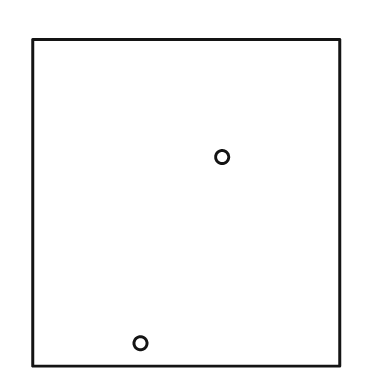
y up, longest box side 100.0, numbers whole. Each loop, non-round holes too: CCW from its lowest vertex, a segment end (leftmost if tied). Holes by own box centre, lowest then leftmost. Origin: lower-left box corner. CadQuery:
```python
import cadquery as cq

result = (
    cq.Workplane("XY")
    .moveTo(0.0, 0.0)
    .lineTo(94.0, 0.0)
    .lineTo(94.0, 100.0)
    .lineTo(0.0, 100.0)
    .close()
    .moveTo(33.0, 7.0)
    .circle(2.0)
    .moveTo(58.0, 64.0)
    .circle(2.0)
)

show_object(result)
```